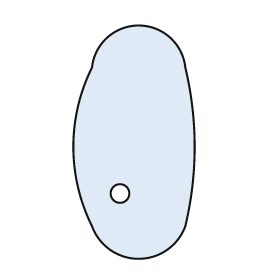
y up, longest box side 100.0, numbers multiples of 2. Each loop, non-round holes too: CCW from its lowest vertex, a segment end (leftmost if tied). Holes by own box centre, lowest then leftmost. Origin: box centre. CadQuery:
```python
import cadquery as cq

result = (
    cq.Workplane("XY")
    .moveTo(-18.0, -36.0)
    .threePointArc((2.0, -50.0), (22.0, -36.0))
    .threePointArc((26.0, -2.0), (22.0, 32.0))
    .threePointArc((2.0, 50.0), (-18.0, 32.0))
    .threePointArc((-26.0, -2.0), (-18.0, -36.0))
    .close()
    .moveTo(-6.0, -22.0)
    .circle(4.0)
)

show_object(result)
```